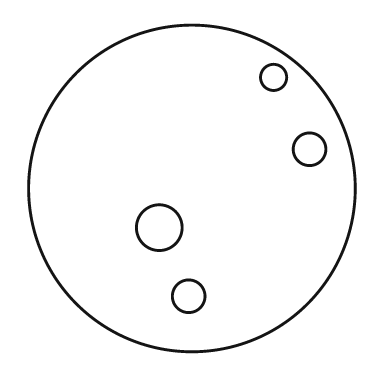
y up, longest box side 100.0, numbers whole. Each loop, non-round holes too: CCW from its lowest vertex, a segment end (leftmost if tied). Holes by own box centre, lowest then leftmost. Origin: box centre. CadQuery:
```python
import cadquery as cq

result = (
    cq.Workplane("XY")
    .moveTo(0.0, 0.0)
    .circle(50.0)
    .moveTo(-1.0, -33.0)
    .circle(5.0)
    .moveTo(-10.0, -12.0)
    .circle(7.0)
    .moveTo(36.0, 12.0)
    .circle(5.0)
    .moveTo(25.0, 34.0)
    .circle(4.0)
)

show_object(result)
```